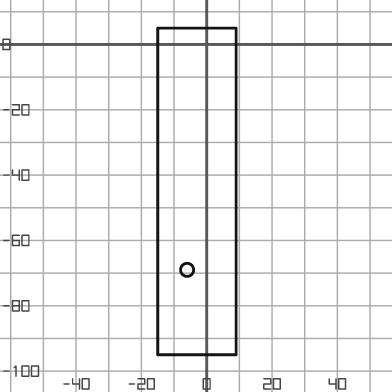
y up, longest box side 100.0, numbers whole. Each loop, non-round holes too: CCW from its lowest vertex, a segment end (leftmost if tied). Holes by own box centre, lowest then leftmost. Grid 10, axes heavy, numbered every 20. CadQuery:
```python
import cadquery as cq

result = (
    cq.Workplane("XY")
    .moveTo(-15.0, -95.0)
    .lineTo(9.0, -95.0)
    .lineTo(9.0, 5.0)
    .lineTo(-15.0, 5.0)
    .close()
    .moveTo(-6.0, -69.0)
    .circle(2.0)
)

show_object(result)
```